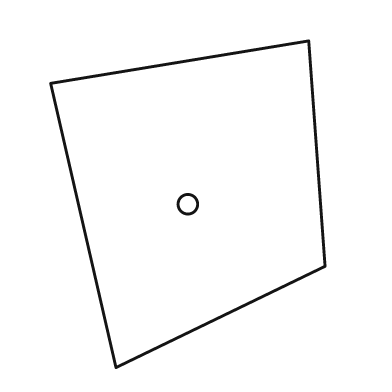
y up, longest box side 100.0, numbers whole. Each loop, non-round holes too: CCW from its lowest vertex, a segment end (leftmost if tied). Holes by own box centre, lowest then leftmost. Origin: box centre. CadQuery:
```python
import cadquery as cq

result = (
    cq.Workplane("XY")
    .moveTo(-22.0, -50.0)
    .lineTo(42.0, -19.0)
    .lineTo(37.0, 50.0)
    .lineTo(-42.0, 37.0)
    .close()
    .moveTo(0.0, 0.0)
    .circle(3.0)
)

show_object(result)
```